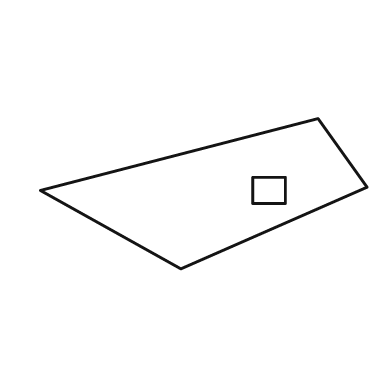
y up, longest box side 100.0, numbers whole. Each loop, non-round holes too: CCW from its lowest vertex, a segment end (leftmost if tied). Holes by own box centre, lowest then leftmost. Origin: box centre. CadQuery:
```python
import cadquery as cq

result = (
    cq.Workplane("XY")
    .moveTo(-7.0, -23.0)
    .lineTo(50.0, 2.0)
    .lineTo(35.0, 23.0)
    .lineTo(-50.0, 1.0)
    .close()
    .moveTo(15.0, -3.0)
    .lineTo(25.0, -3.0)
    .lineTo(25.0, 5.0)
    .lineTo(15.0, 5.0)
    .close()
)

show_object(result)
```